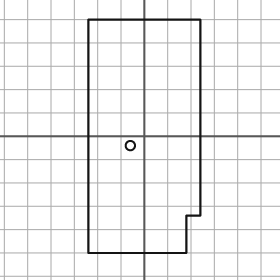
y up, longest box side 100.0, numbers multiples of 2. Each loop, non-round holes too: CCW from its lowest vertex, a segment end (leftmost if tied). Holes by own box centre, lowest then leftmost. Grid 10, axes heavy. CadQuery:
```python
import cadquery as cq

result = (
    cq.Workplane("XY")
    .moveTo(-24.0, -50.0)
    .lineTo(18.0, -50.0)
    .lineTo(18.0, -34.0)
    .lineTo(24.0, -34.0)
    .lineTo(24.0, 50.0)
    .lineTo(-24.0, 50.0)
    .close()
    .moveTo(-6.0, -4.0)
    .circle(2.0)
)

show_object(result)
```